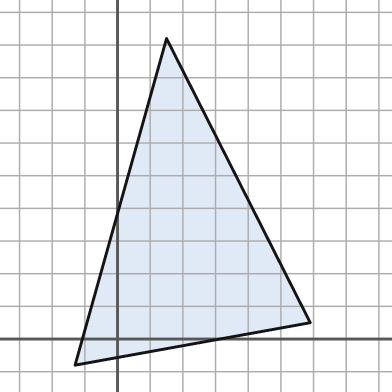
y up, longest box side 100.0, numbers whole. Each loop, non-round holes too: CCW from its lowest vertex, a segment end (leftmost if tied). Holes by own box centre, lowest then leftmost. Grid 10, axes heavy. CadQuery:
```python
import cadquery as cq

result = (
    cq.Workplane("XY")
    .moveTo(-13.0, -8.0)
    .lineTo(59.0, 5.0)
    .lineTo(15.0, 92.0)
    .close()
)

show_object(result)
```